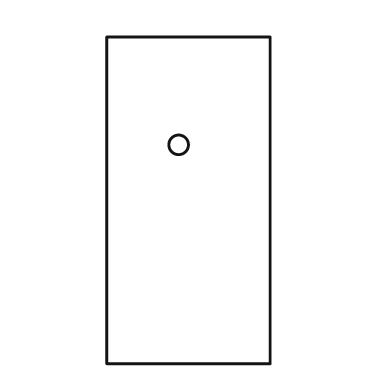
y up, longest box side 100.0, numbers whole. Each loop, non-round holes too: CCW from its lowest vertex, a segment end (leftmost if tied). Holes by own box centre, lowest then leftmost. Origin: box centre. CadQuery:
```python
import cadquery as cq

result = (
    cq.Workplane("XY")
    .moveTo(-25.0, -50.0)
    .lineTo(25.0, -50.0)
    .lineTo(25.0, 50.0)
    .lineTo(-25.0, 50.0)
    .close()
    .moveTo(-3.0, 17.0)
    .circle(3.0)
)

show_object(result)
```